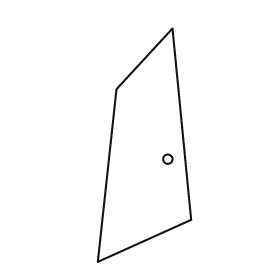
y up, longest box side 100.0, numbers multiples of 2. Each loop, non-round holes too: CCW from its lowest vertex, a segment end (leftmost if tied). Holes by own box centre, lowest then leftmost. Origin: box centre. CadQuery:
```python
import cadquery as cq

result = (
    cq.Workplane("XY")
    .moveTo(-20.0, -50.0)
    .lineTo(20.0, -32.0)
    .lineTo(12.0, 50.0)
    .lineTo(-12.0, 24.0)
    .close()
    .moveTo(10.0, -6.0)
    .circle(2.0)
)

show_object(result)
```